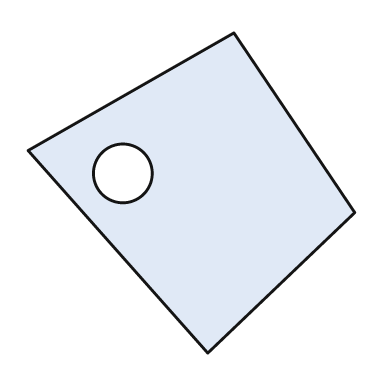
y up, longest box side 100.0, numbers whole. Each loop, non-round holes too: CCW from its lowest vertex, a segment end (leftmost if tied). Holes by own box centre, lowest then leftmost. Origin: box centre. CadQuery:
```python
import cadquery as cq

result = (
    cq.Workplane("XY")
    .moveTo(5.0, -49.0)
    .lineTo(50.0, -6.0)
    .lineTo(13.0, 49.0)
    .lineTo(-50.0, 13.0)
    .close()
    .moveTo(-21.0, 6.0)
    .circle(9.0)
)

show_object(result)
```